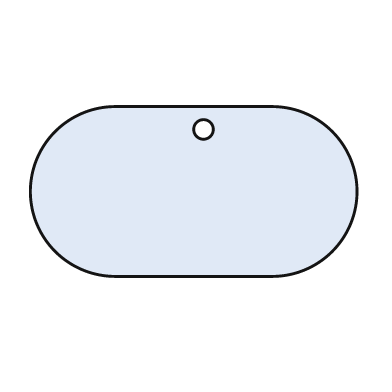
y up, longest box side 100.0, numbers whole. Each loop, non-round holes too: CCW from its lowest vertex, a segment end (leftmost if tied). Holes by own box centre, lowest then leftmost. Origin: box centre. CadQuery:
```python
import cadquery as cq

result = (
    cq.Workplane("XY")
    .moveTo(-24.0, -26.0)
    .lineTo(24.0, -26.0)
    .threePointArc((50.0, 0.0), (24.0, 26.0))
    .lineTo(-24.0, 26.0)
    .threePointArc((-50.0, 0.0), (-24.0, -26.0))
    .close()
    .moveTo(3.0, 19.0)
    .circle(3.0)
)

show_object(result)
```